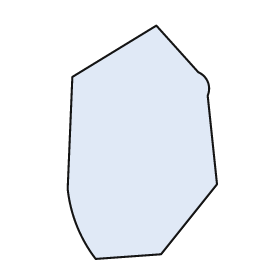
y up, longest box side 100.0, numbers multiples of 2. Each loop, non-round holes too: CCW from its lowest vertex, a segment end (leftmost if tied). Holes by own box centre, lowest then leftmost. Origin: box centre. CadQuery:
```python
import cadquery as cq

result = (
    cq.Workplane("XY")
    .moveTo(-20.0, -50.0)
    .lineTo(8.0, -48.0)
    .lineTo(32.0, -18.0)
    .lineTo(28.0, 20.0)
    .threePointArc((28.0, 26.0), (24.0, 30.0))
    .lineTo(6.0, 50.0)
    .lineTo(-30.0, 28.0)
    .lineTo(-32.0, -20.0)
    .threePointArc((-28.0, -36.0), (-20.0, -50.0))
    .close()
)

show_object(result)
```